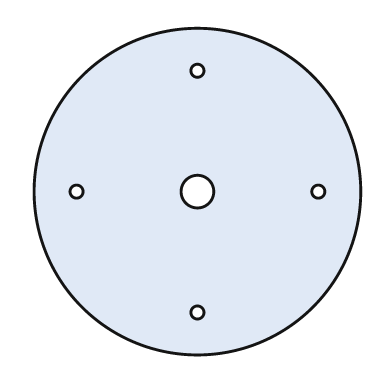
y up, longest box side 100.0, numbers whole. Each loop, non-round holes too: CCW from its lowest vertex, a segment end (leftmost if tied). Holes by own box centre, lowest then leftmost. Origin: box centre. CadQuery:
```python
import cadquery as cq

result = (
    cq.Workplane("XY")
    .moveTo(0.0, 0.0)
    .circle(50.0)
    .moveTo(0.0, -37.0)
    .circle(2.0)
    .moveTo(-37.0, 0.0)
    .circle(2.0)
    .moveTo(0.0, 0.0)
    .circle(5.0)
    .moveTo(37.0, 0.0)
    .circle(2.0)
    .moveTo(0.0, 37.0)
    .circle(2.0)
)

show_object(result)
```